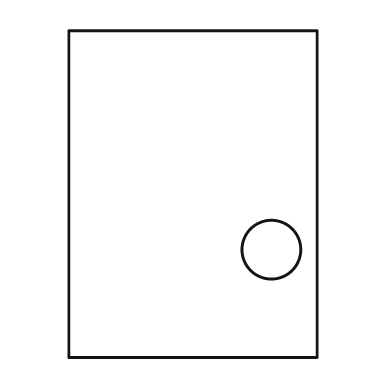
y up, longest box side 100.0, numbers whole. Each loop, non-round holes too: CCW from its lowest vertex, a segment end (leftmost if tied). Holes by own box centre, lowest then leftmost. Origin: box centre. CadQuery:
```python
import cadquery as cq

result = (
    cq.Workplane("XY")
    .moveTo(-38.0, -50.0)
    .lineTo(38.0, -50.0)
    .lineTo(38.0, 50.0)
    .lineTo(-38.0, 50.0)
    .close()
    .moveTo(24.0, -17.0)
    .circle(9.0)
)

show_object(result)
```